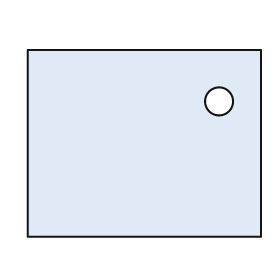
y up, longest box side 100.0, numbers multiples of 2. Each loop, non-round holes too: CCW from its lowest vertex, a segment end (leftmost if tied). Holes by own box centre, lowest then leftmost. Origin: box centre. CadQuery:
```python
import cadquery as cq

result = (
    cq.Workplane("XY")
    .moveTo(-50.0, -40.0)
    .lineTo(50.0, -40.0)
    .lineTo(50.0, 40.0)
    .lineTo(-50.0, 40.0)
    .close()
    .moveTo(32.0, 18.0)
    .circle(6.0)
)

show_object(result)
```